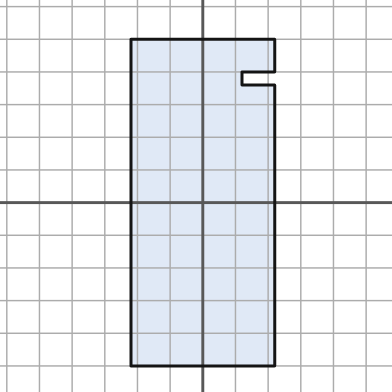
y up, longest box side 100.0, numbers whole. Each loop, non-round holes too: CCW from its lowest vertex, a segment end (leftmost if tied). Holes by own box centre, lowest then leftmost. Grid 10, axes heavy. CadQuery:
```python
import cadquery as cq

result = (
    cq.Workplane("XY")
    .moveTo(-22.0, -50.0)
    .lineTo(22.0, -50.0)
    .lineTo(22.0, 36.0)
    .lineTo(12.0, 36.0)
    .lineTo(12.0, 40.0)
    .lineTo(22.0, 40.0)
    .lineTo(22.0, 50.0)
    .lineTo(-22.0, 50.0)
    .close()
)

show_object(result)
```